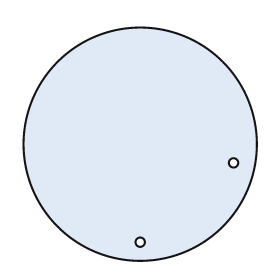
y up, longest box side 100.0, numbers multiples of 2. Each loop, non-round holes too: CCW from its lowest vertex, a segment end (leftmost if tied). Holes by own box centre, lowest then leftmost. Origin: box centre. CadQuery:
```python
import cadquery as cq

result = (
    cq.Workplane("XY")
    .moveTo(0.0, 0.0)
    .circle(50.0)
    .moveTo(0.0, -42.0)
    .circle(2.0)
    .moveTo(40.0, -8.0)
    .circle(2.0)
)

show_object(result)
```